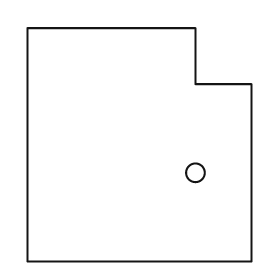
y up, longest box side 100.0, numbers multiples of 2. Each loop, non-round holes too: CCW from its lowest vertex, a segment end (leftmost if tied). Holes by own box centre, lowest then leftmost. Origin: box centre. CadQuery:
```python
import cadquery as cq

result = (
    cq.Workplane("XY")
    .moveTo(-48.0, -50.0)
    .lineTo(48.0, -50.0)
    .lineTo(48.0, 26.0)
    .lineTo(24.0, 26.0)
    .lineTo(24.0, 50.0)
    .lineTo(-48.0, 50.0)
    .close()
    .moveTo(24.0, -12.0)
    .circle(4.0)
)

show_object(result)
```